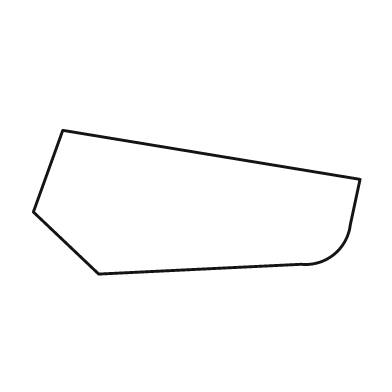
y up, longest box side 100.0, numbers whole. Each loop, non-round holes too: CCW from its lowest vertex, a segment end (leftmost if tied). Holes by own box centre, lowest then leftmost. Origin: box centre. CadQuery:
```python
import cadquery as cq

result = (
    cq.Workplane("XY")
    .moveTo(-30.0, -22.0)
    .lineTo(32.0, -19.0)
    .threePointArc((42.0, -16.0), (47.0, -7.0))
    .lineTo(50.0, 7.0)
    .lineTo(-41.0, 22.0)
    .lineTo(-50.0, -3.0)
    .close()
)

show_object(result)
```